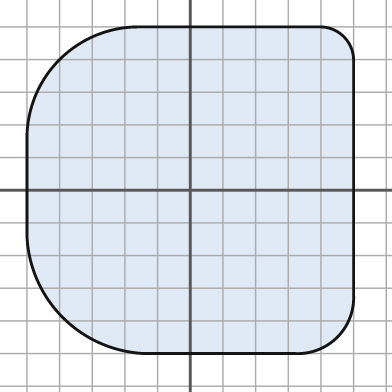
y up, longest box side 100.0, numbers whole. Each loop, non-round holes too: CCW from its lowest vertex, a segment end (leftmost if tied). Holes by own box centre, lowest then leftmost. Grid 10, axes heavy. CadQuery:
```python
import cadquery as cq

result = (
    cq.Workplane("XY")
    .moveTo(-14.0, -50.0)
    .lineTo(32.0, -50.0)
    .threePointArc((45.0, -45.0), (50.0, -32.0))
    .lineTo(50.0, 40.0)
    .threePointArc((47.0, 47.0), (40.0, 50.0))
    .lineTo(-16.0, 50.0)
    .threePointArc((-40.0, 40.0), (-50.0, 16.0))
    .lineTo(-50.0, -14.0)
    .threePointArc((-39.0, -39.0), (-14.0, -50.0))
    .close()
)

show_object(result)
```